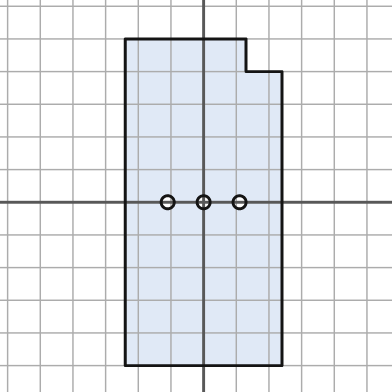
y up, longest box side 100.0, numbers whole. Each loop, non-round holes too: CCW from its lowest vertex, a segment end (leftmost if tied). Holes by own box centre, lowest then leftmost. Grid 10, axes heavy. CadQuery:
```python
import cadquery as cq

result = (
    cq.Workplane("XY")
    .moveTo(-24.0, -50.0)
    .lineTo(24.0, -50.0)
    .lineTo(24.0, 40.0)
    .lineTo(13.0, 40.0)
    .lineTo(13.0, 50.0)
    .lineTo(-24.0, 50.0)
    .close()
    .moveTo(-11.0, 0.0)
    .circle(2.0)
    .moveTo(0.0, 0.0)
    .circle(2.0)
    .moveTo(11.0, 0.0)
    .circle(2.0)
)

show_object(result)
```